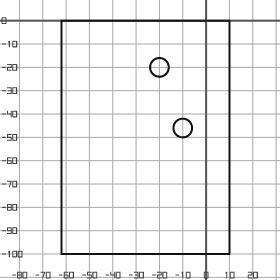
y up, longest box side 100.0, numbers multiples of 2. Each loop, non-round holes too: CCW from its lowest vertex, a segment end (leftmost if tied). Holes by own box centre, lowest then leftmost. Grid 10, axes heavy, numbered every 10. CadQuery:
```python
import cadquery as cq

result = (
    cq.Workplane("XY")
    .moveTo(-62.0, -100.0)
    .lineTo(10.0, -100.0)
    .lineTo(10.0, 0.0)
    .lineTo(-62.0, 0.0)
    .close()
    .moveTo(-10.0, -46.0)
    .circle(4.0)
    .moveTo(-20.0, -20.0)
    .circle(4.0)
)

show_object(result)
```